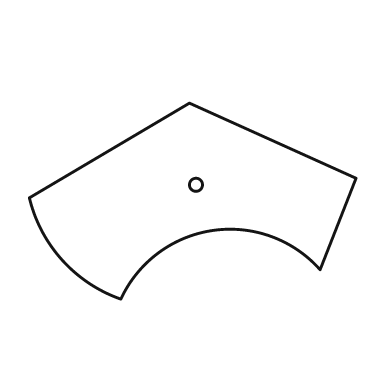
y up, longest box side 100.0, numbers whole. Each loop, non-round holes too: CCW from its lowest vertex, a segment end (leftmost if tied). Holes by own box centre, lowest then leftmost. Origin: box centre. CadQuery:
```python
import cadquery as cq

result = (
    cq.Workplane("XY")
    .moveTo(-22.0, -30.0)
    .threePointArc((6.0, -9.0), (39.0, -21.0))
    .lineTo(50.0, 7.0)
    .lineTo(-1.0, 30.0)
    .lineTo(-50.0, 1.0)
    .threePointArc((-40.0, -18.0), (-22.0, -30.0))
    .close()
    .moveTo(1.0, 5.0)
    .circle(2.0)
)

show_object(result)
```